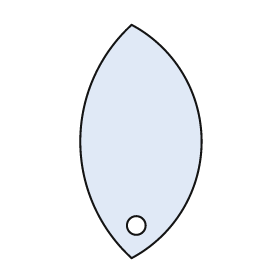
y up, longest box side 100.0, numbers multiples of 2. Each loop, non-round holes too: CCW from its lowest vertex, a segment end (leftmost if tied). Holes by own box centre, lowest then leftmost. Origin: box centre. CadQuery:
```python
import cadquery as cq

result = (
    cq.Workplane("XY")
    .moveTo(-4.0, -50.0)
    .threePointArc((26.0, 0.0), (-4.0, 50.0))
    .threePointArc((-26.0, 0.0), (-4.0, -50.0))
    .close()
    .moveTo(-2.0, -36.0)
    .circle(4.0)
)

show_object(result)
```